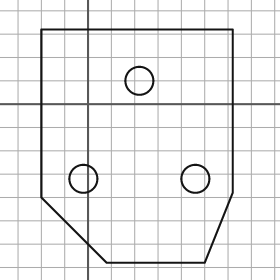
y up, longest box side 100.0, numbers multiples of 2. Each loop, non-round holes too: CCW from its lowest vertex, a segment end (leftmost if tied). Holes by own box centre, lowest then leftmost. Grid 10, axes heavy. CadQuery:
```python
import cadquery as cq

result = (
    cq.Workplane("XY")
    .moveTo(8.0, -68.0)
    .lineTo(50.0, -68.0)
    .lineTo(62.0, -38.0)
    .lineTo(62.0, 32.0)
    .lineTo(-20.0, 32.0)
    .lineTo(-20.0, -40.0)
    .close()
    .moveTo(-2.0, -32.0)
    .circle(6.0)
    .moveTo(46.0, -32.0)
    .circle(6.0)
    .moveTo(22.0, 10.0)
    .circle(6.0)
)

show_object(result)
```